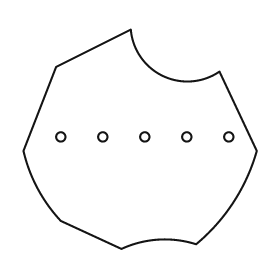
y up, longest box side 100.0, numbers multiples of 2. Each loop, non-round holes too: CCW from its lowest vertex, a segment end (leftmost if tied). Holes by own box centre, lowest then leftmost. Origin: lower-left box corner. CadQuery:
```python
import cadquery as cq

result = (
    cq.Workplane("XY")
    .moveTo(42.0, 0.0)
    .threePointArc((58.0, 4.0), (74.0, 2.0))
    .threePointArc((90.0, 20.0), (100.0, 42.0))
    .lineTo(84.0, 76.0)
    .threePointArc((60.0, 74.0), (46.0, 94.0))
    .lineTo(14.0, 78.0)
    .lineTo(0.0, 42.0)
    .threePointArc((6.0, 26.0), (16.0, 12.0))
    .close()
    .moveTo(16.0, 48.0)
    .circle(2.0)
    .moveTo(34.0, 48.0)
    .circle(2.0)
    .moveTo(52.0, 48.0)
    .circle(2.0)
    .moveTo(70.0, 48.0)
    .circle(2.0)
    .moveTo(88.0, 48.0)
    .circle(2.0)
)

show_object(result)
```